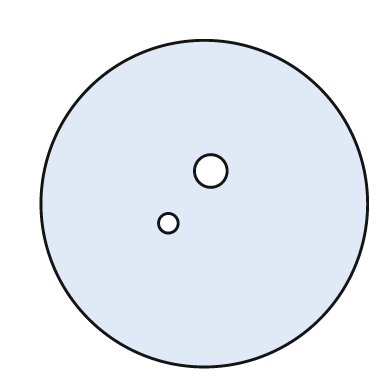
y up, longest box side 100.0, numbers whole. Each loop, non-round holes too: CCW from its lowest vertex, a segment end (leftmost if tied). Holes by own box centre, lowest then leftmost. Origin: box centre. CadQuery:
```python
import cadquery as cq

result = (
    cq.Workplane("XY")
    .moveTo(0.0, 0.0)
    .circle(50.0)
    .moveTo(-11.0, -6.0)
    .circle(3.0)
    .moveTo(2.0, 10.0)
    .circle(5.0)
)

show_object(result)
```